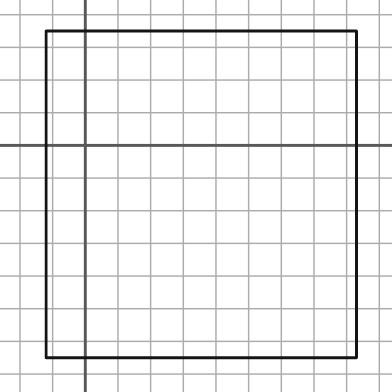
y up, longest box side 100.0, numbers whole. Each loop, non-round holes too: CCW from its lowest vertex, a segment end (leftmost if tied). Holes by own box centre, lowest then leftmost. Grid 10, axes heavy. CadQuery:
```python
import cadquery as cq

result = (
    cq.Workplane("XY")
    .moveTo(-12.0, -65.0)
    .lineTo(83.0, -65.0)
    .lineTo(83.0, 35.0)
    .lineTo(-12.0, 35.0)
    .close()
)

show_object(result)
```